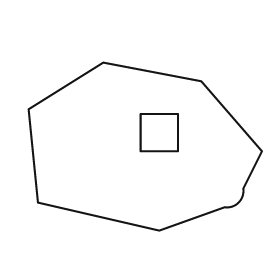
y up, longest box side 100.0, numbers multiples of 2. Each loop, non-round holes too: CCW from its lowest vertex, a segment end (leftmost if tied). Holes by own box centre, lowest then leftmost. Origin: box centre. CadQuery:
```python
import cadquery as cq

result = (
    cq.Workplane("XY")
    .moveTo(6.0, -36.0)
    .lineTo(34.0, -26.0)
    .threePointArc((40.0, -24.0), (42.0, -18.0))
    .lineTo(50.0, -2.0)
    .lineTo(24.0, 28.0)
    .lineTo(-18.0, 36.0)
    .lineTo(-50.0, 16.0)
    .lineTo(-46.0, -24.0)
    .close()
    .moveTo(-2.0, -2.0)
    .lineTo(14.0, -2.0)
    .lineTo(14.0, 14.0)
    .lineTo(-2.0, 14.0)
    .close()
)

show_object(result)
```